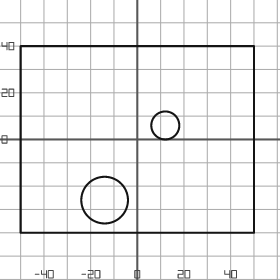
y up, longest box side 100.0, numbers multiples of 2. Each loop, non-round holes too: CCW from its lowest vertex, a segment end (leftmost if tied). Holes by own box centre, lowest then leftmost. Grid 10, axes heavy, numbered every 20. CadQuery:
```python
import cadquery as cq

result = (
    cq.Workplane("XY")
    .moveTo(-50.0, -40.0)
    .lineTo(50.0, -40.0)
    .lineTo(50.0, 40.0)
    .lineTo(-50.0, 40.0)
    .close()
    .moveTo(-14.0, -26.0)
    .circle(10.0)
    .moveTo(12.0, 6.0)
    .circle(6.0)
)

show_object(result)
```